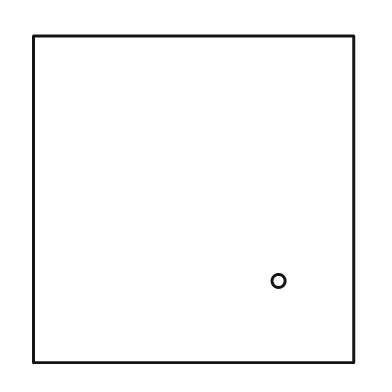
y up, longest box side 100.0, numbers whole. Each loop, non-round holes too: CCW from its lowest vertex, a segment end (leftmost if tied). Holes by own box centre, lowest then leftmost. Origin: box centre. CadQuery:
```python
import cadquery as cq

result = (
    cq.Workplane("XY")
    .moveTo(-49.0, -50.0)
    .lineTo(49.0, -50.0)
    .lineTo(49.0, 50.0)
    .lineTo(-49.0, 50.0)
    .close()
    .moveTo(26.0, -25.0)
    .circle(2.0)
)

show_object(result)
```